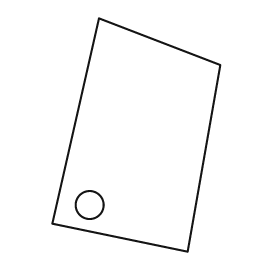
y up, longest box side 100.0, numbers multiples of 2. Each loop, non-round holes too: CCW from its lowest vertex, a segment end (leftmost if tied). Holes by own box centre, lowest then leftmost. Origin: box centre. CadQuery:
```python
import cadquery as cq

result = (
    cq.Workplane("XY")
    .moveTo(22.0, -50.0)
    .lineTo(36.0, 30.0)
    .lineTo(-16.0, 50.0)
    .lineTo(-36.0, -38.0)
    .close()
    .moveTo(-20.0, -30.0)
    .circle(6.0)
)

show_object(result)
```